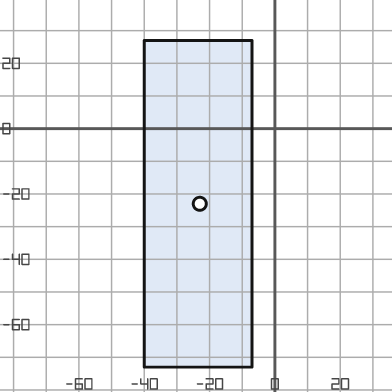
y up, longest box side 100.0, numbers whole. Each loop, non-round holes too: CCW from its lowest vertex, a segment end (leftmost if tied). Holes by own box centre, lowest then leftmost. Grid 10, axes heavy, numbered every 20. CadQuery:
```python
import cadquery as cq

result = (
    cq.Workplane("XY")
    .moveTo(-40.0, -73.0)
    .lineTo(-7.0, -73.0)
    .lineTo(-7.0, 27.0)
    .lineTo(-40.0, 27.0)
    .close()
    .moveTo(-23.0, -23.0)
    .circle(2.0)
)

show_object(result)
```